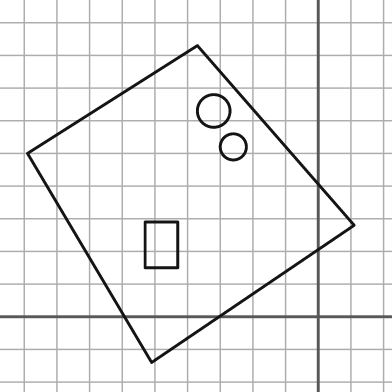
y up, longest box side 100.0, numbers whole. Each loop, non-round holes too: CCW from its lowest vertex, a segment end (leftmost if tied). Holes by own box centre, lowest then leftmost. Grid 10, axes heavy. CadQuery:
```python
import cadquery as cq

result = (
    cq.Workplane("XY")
    .moveTo(-51.0, -14.0)
    .lineTo(11.0, 28.0)
    .lineTo(-37.0, 83.0)
    .lineTo(-89.0, 50.0)
    .close()
    .moveTo(-53.0, 15.0)
    .lineTo(-43.0, 15.0)
    .lineTo(-43.0, 29.0)
    .lineTo(-53.0, 29.0)
    .close()
    .moveTo(-26.0, 52.0)
    .circle(4.0)
    .moveTo(-32.0, 63.0)
    .circle(5.0)
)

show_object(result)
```